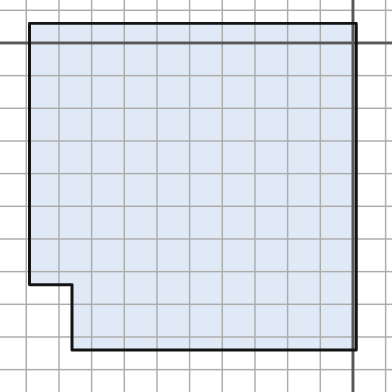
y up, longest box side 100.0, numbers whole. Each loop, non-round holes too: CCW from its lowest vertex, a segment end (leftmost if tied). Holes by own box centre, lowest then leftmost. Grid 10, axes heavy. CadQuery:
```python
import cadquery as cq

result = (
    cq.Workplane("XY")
    .moveTo(-86.0, -94.0)
    .lineTo(1.0, -94.0)
    .lineTo(1.0, 6.0)
    .lineTo(-99.0, 6.0)
    .lineTo(-99.0, -74.0)
    .lineTo(-86.0, -74.0)
    .close()
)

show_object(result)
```